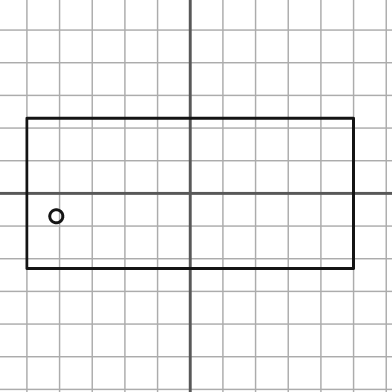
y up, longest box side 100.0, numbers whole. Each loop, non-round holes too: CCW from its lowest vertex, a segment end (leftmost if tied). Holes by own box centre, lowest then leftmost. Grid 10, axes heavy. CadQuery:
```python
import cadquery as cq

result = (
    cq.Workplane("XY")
    .moveTo(-50.0, -23.0)
    .lineTo(50.0, -23.0)
    .lineTo(50.0, 23.0)
    .lineTo(-50.0, 23.0)
    .close()
    .moveTo(-41.0, -7.0)
    .circle(2.0)
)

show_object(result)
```